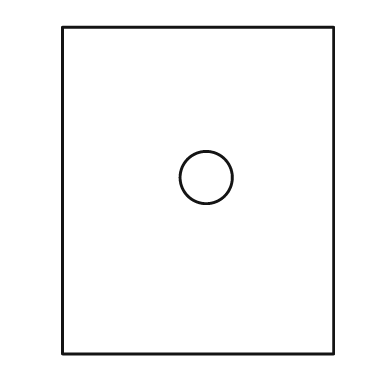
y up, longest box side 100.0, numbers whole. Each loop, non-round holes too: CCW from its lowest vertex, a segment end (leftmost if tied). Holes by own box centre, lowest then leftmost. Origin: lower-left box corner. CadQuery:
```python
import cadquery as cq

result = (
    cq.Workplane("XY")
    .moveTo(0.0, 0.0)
    .lineTo(83.0, 0.0)
    .lineTo(83.0, 100.0)
    .lineTo(0.0, 100.0)
    .close()
    .moveTo(44.0, 54.0)
    .circle(8.0)
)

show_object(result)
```